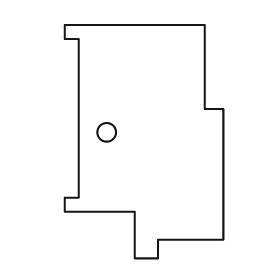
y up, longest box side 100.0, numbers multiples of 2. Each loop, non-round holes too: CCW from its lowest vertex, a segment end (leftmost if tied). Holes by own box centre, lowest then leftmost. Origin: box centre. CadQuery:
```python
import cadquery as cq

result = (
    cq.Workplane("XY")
    .moveTo(-4.0, -50.0)
    .lineTo(6.0, -50.0)
    .lineTo(6.0, -42.0)
    .lineTo(34.0, -42.0)
    .lineTo(34.0, 14.0)
    .lineTo(26.0, 14.0)
    .lineTo(26.0, 50.0)
    .lineTo(-34.0, 50.0)
    .lineTo(-34.0, 44.0)
    .lineTo(-28.0, 44.0)
    .lineTo(-28.0, -24.0)
    .lineTo(-34.0, -24.0)
    .lineTo(-34.0, -30.0)
    .lineTo(-4.0, -30.0)
    .close()
    .moveTo(-16.0, 4.0)
    .circle(4.0)
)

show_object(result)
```